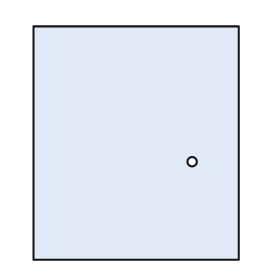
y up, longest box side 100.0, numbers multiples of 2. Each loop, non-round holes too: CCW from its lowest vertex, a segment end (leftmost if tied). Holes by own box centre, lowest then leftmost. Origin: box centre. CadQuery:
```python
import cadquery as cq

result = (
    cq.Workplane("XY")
    .moveTo(-44.0, -50.0)
    .lineTo(44.0, -50.0)
    .lineTo(44.0, 50.0)
    .lineTo(-44.0, 50.0)
    .close()
    .moveTo(24.0, -8.0)
    .circle(2.0)
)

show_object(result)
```